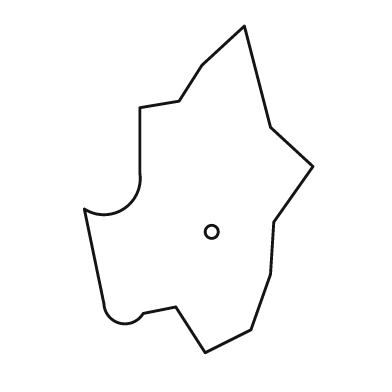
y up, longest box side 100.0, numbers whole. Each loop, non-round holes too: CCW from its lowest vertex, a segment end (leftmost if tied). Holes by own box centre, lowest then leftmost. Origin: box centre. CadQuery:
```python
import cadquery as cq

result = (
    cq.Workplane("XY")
    .moveTo(2.0, -50.0)
    .lineTo(16.0, -43.0)
    .lineTo(22.0, -26.0)
    .lineTo(23.0, -10.0)
    .lineTo(35.0, 7.0)
    .lineTo(22.0, 19.0)
    .lineTo(14.0, 50.0)
    .lineTo(1.0, 38.0)
    .lineTo(-6.0, 27.0)
    .lineTo(-18.0, 25.0)
    .lineTo(-18.0, 5.0)
    .threePointArc((-23.0, -6.0), (-35.0, -6.0))
    .lineTo(-29.0, -35.0)
    .threePointArc((-24.0, -41.0), (-17.0, -38.0))
    .lineTo(-7.0, -36.0)
    .close()
    .moveTo(4.0, -13.0)
    .circle(2.0)
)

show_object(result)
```